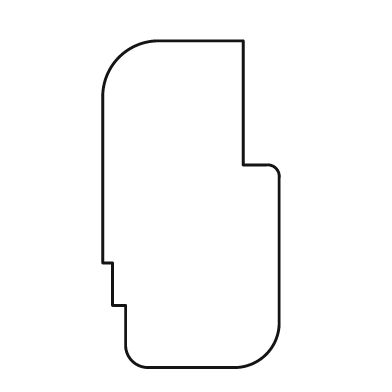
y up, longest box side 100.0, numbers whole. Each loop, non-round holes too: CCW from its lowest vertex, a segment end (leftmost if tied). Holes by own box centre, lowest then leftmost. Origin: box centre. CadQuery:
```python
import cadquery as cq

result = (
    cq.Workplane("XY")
    .moveTo(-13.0, -50.0)
    .lineTo(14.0, -50.0)
    .threePointArc((23.0, -46.0), (27.0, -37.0))
    .lineTo(27.0, 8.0)
    .threePointArc((26.0, 11.0), (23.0, 12.0))
    .lineTo(16.0, 12.0)
    .lineTo(16.0, 50.0)
    .lineTo(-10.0, 50.0)
    .threePointArc((-22.0, 45.0), (-27.0, 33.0))
    .lineTo(-27.0, -18.0)
    .lineTo(-24.0, -18.0)
    .lineTo(-24.0, -31.0)
    .lineTo(-20.0, -31.0)
    .lineTo(-20.0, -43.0)
    .threePointArc((-18.0, -48.0), (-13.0, -50.0))
    .close()
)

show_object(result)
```